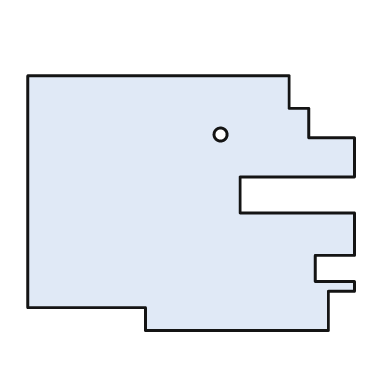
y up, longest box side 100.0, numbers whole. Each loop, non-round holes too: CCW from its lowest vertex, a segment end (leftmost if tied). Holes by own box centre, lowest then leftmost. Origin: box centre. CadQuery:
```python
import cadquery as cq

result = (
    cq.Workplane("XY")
    .moveTo(-14.0, -39.0)
    .lineTo(42.0, -39.0)
    .lineTo(42.0, -27.0)
    .lineTo(50.0, -27.0)
    .lineTo(50.0, -24.0)
    .lineTo(38.0, -24.0)
    .lineTo(38.0, -16.0)
    .lineTo(50.0, -16.0)
    .lineTo(50.0, -3.0)
    .lineTo(15.0, -3.0)
    .lineTo(15.0, 8.0)
    .lineTo(50.0, 8.0)
    .lineTo(50.0, 20.0)
    .lineTo(36.0, 20.0)
    .lineTo(36.0, 29.0)
    .lineTo(30.0, 29.0)
    .lineTo(30.0, 39.0)
    .lineTo(-50.0, 39.0)
    .lineTo(-50.0, -32.0)
    .lineTo(-14.0, -32.0)
    .close()
    .moveTo(9.0, 21.0)
    .circle(2.0)
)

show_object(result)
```